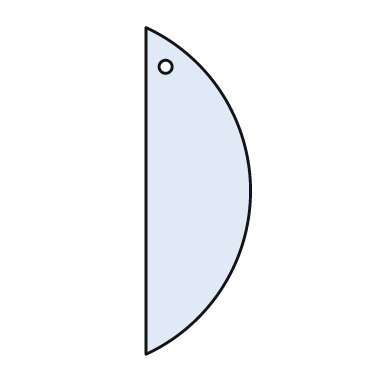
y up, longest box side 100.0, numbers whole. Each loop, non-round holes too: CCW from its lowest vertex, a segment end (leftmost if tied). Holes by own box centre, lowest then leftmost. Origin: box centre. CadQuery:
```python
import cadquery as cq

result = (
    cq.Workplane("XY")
    .moveTo(-16.0, -50.0)
    .threePointArc((16.0, 0.0), (-16.0, 50.0))
    .close()
    .moveTo(-10.0, 38.0)
    .circle(2.0)
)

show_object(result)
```